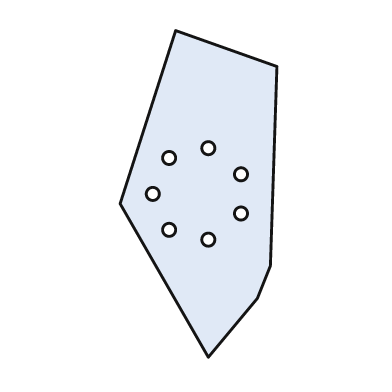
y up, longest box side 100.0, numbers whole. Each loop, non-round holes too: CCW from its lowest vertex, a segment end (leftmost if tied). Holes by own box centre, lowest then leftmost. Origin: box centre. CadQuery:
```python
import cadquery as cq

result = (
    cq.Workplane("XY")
    .moveTo(3.0, -50.0)
    .lineTo(18.0, -32.0)
    .lineTo(22.0, -22.0)
    .lineTo(24.0, 39.0)
    .lineTo(-7.0, 50.0)
    .lineTo(-24.0, -3.0)
    .close()
    .moveTo(3.0, -14.0)
    .circle(2.0)
    .moveTo(-9.0, -11.0)
    .circle(2.0)
    .moveTo(13.0, -6.0)
    .circle(2.0)
    .moveTo(-14.0, 0.0)
    .circle(2.0)
    .moveTo(13.0, 6.0)
    .circle(2.0)
    .moveTo(-9.0, 11.0)
    .circle(2.0)
    .moveTo(3.0, 14.0)
    .circle(2.0)
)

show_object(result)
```